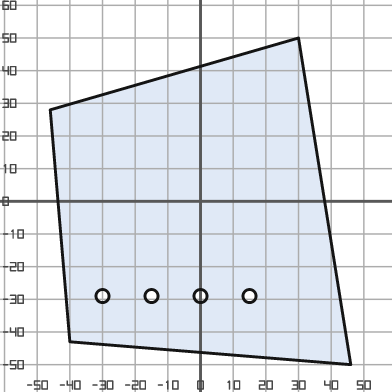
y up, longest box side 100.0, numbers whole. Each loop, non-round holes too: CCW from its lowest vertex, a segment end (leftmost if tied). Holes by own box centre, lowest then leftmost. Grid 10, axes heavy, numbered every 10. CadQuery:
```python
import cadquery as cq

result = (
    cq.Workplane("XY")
    .moveTo(46.0, -50.0)
    .lineTo(30.0, 50.0)
    .lineTo(-46.0, 28.0)
    .lineTo(-40.0, -43.0)
    .close()
    .moveTo(-30.0, -29.0)
    .circle(2.0)
    .moveTo(-15.0, -29.0)
    .circle(2.0)
    .moveTo(0.0, -29.0)
    .circle(2.0)
    .moveTo(15.0, -29.0)
    .circle(2.0)
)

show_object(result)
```